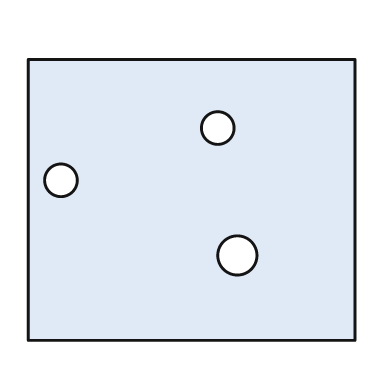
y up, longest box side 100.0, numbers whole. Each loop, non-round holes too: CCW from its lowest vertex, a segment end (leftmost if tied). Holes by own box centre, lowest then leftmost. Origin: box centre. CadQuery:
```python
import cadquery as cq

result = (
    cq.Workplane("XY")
    .moveTo(-50.0, -43.0)
    .lineTo(50.0, -43.0)
    .lineTo(50.0, 43.0)
    .lineTo(-50.0, 43.0)
    .close()
    .moveTo(14.0, -17.0)
    .circle(6.0)
    .moveTo(-40.0, 6.0)
    .circle(5.0)
    .moveTo(8.0, 22.0)
    .circle(5.0)
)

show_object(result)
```